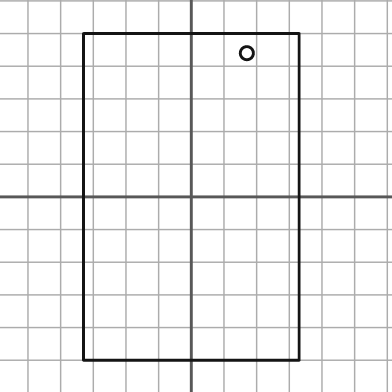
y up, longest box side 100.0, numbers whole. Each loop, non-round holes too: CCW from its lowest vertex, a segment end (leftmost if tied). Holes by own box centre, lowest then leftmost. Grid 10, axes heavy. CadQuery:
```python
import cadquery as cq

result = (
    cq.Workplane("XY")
    .moveTo(-33.0, -50.0)
    .lineTo(33.0, -50.0)
    .lineTo(33.0, 50.0)
    .lineTo(-33.0, 50.0)
    .close()
    .moveTo(17.0, 44.0)
    .circle(2.0)
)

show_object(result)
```